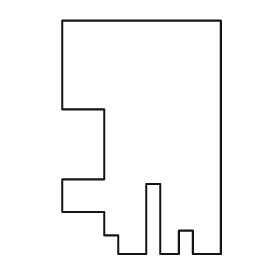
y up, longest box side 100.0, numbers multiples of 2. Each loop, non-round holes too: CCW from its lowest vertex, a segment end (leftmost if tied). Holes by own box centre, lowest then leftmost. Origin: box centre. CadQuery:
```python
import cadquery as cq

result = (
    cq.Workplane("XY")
    .moveTo(-10.0, -50.0)
    .lineTo(2.0, -50.0)
    .lineTo(2.0, -20.0)
    .lineTo(8.0, -20.0)
    .lineTo(8.0, -50.0)
    .lineTo(16.0, -50.0)
    .lineTo(16.0, -40.0)
    .lineTo(22.0, -40.0)
    .lineTo(22.0, -50.0)
    .lineTo(34.0, -50.0)
    .lineTo(34.0, 50.0)
    .lineTo(-34.0, 50.0)
    .lineTo(-34.0, 12.0)
    .lineTo(-16.0, 12.0)
    .lineTo(-16.0, -18.0)
    .lineTo(-34.0, -18.0)
    .lineTo(-34.0, -32.0)
    .lineTo(-16.0, -32.0)
    .lineTo(-16.0, -42.0)
    .lineTo(-10.0, -42.0)
    .close()
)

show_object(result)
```